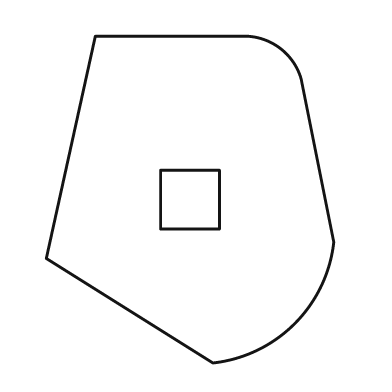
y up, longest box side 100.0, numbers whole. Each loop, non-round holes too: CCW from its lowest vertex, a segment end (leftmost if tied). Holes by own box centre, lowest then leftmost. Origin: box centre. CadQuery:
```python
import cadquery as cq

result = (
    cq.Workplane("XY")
    .moveTo(7.0, -50.0)
    .threePointArc((32.0, -38.0), (44.0, -13.0))
    .lineTo(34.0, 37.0)
    .threePointArc((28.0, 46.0), (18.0, 50.0))
    .lineTo(-29.0, 50.0)
    .lineTo(-44.0, -18.0)
    .close()
    .moveTo(-9.0, -9.0)
    .lineTo(9.0, -9.0)
    .lineTo(9.0, 9.0)
    .lineTo(-9.0, 9.0)
    .close()
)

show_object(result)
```